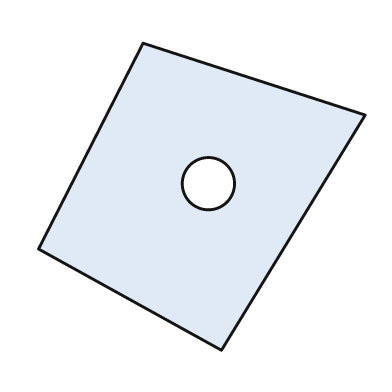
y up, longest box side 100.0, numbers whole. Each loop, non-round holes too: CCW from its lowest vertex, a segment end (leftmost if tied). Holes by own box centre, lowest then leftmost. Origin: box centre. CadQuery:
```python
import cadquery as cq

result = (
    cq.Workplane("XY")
    .moveTo(6.0, -47.0)
    .lineTo(50.0, 25.0)
    .lineTo(-18.0, 47.0)
    .lineTo(-50.0, -16.0)
    .close()
    .moveTo(2.0, 4.0)
    .circle(8.0)
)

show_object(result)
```